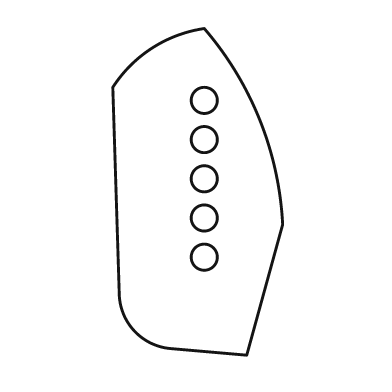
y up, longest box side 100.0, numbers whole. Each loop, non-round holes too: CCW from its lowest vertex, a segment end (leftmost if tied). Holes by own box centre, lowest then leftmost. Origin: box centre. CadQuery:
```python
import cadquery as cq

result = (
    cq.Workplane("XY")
    .moveTo(15.0, -50.0)
    .lineTo(26.0, -10.0)
    .threePointArc((19.0, 22.0), (2.0, 50.0))
    .threePointArc((-14.0, 44.0), (-26.0, 32.0))
    .lineTo(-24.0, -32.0)
    .threePointArc((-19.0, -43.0), (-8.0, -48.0))
    .close()
    .moveTo(2.0, -20.0)
    .circle(4.0)
    .moveTo(2.0, -8.0)
    .circle(4.0)
    .moveTo(2.0, 4.0)
    .circle(4.0)
    .moveTo(2.0, 16.0)
    .circle(4.0)
    .moveTo(2.0, 28.0)
    .circle(4.0)
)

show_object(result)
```